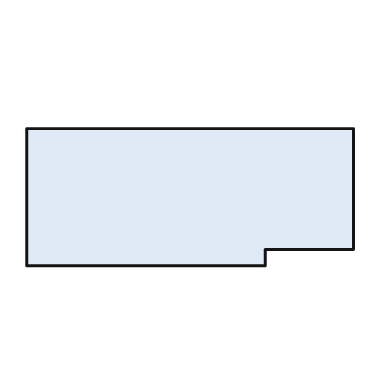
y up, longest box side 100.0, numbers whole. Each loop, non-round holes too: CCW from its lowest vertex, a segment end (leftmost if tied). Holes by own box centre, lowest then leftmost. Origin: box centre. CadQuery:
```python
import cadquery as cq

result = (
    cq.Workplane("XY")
    .moveTo(-50.0, -21.0)
    .lineTo(23.0, -21.0)
    .lineTo(23.0, -16.0)
    .lineTo(50.0, -16.0)
    .lineTo(50.0, 21.0)
    .lineTo(-50.0, 21.0)
    .close()
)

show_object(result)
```